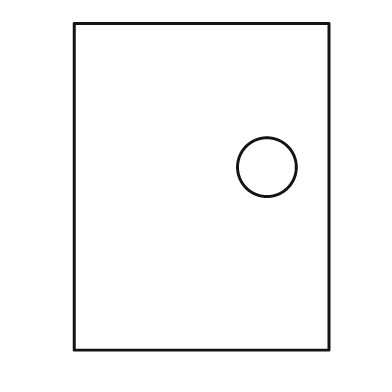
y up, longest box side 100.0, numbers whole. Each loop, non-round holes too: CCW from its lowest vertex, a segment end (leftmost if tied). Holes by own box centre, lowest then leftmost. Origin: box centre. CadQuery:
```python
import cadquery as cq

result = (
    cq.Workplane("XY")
    .moveTo(-39.0, -50.0)
    .lineTo(39.0, -50.0)
    .lineTo(39.0, 50.0)
    .lineTo(-39.0, 50.0)
    .close()
    .moveTo(20.0, 6.0)
    .circle(9.0)
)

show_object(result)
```